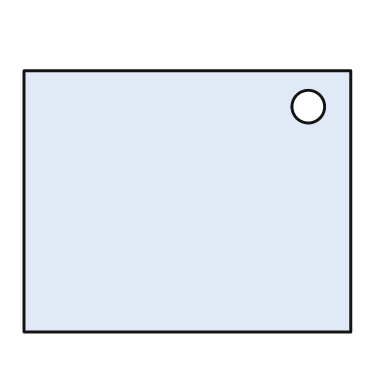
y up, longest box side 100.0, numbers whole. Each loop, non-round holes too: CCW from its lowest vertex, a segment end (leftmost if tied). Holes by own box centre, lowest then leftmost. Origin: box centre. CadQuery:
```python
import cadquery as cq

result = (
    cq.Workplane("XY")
    .moveTo(-50.0, -40.0)
    .lineTo(50.0, -40.0)
    .lineTo(50.0, 40.0)
    .lineTo(-50.0, 40.0)
    .close()
    .moveTo(37.0, 29.0)
    .circle(5.0)
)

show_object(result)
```